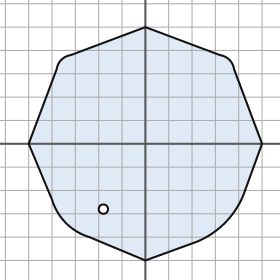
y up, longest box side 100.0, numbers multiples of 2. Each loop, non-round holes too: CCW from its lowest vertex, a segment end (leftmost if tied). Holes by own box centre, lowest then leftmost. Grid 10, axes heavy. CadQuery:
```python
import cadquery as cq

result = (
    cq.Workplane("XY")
    .moveTo(0.0, -50.0)
    .lineTo(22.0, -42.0)
    .threePointArc((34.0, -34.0), (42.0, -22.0))
    .lineTo(50.0, 0.0)
    .lineTo(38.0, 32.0)
    .threePointArc((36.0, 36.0), (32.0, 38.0))
    .lineTo(0.0, 50.0)
    .lineTo(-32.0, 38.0)
    .threePointArc((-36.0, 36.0), (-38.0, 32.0))
    .lineTo(-50.0, 0.0)
    .lineTo(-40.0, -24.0)
    .threePointArc((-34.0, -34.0), (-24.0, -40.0))
    .close()
    .moveTo(-18.0, -28.0)
    .circle(2.0)
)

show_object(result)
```